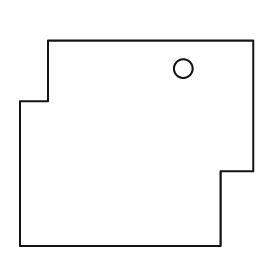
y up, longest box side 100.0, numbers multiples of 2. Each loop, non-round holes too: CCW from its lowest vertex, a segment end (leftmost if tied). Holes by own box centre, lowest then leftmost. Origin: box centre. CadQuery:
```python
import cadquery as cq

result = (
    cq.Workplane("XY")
    .moveTo(-50.0, -44.0)
    .lineTo(36.0, -44.0)
    .lineTo(36.0, -12.0)
    .lineTo(50.0, -12.0)
    .lineTo(50.0, 44.0)
    .lineTo(-38.0, 44.0)
    .lineTo(-38.0, 18.0)
    .lineTo(-50.0, 18.0)
    .close()
    .moveTo(20.0, 32.0)
    .circle(4.0)
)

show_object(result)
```